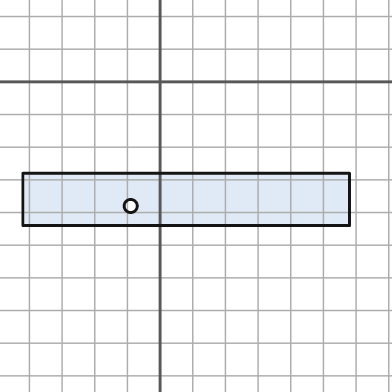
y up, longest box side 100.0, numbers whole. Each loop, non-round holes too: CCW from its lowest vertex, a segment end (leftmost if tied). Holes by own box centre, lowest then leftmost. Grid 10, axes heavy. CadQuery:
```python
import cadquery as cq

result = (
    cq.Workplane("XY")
    .moveTo(-42.0, -44.0)
    .lineTo(58.0, -44.0)
    .lineTo(58.0, -28.0)
    .lineTo(-42.0, -28.0)
    .close()
    .moveTo(-9.0, -38.0)
    .circle(2.0)
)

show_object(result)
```